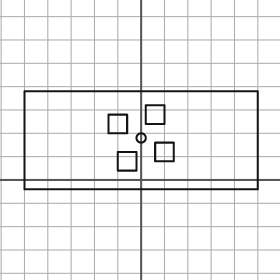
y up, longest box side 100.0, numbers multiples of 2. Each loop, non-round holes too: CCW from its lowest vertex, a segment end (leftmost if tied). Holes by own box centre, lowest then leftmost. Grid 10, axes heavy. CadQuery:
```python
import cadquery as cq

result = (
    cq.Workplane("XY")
    .moveTo(-50.0, -4.0)
    .lineTo(50.0, -4.0)
    .lineTo(50.0, 38.0)
    .lineTo(-50.0, 38.0)
    .close()
    .moveTo(-10.0, 4.0)
    .lineTo(-2.0, 4.0)
    .lineTo(-2.0, 12.0)
    .lineTo(-10.0, 12.0)
    .close()
    .moveTo(6.0, 8.0)
    .lineTo(14.0, 8.0)
    .lineTo(14.0, 16.0)
    .lineTo(6.0, 16.0)
    .close()
    .moveTo(0.0, 18.0)
    .circle(2.0)
    .moveTo(-14.0, 20.0)
    .lineTo(-6.0, 20.0)
    .lineTo(-6.0, 28.0)
    .lineTo(-14.0, 28.0)
    .close()
    .moveTo(2.0, 24.0)
    .lineTo(10.0, 24.0)
    .lineTo(10.0, 32.0)
    .lineTo(2.0, 32.0)
    .close()
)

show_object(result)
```